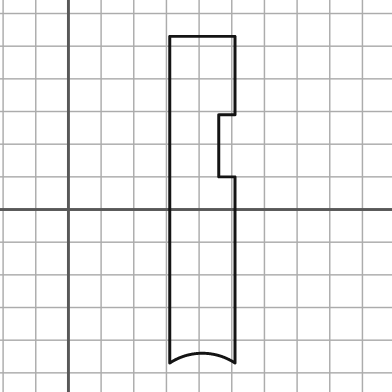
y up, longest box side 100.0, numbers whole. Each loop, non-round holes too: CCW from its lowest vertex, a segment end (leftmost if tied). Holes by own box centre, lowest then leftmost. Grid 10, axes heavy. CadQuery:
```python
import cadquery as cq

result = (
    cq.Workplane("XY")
    .moveTo(31.0, -47.0)
    .threePointArc((41.0, -44.0), (51.0, -47.0))
    .lineTo(51.0, 10.0)
    .lineTo(46.0, 10.0)
    .lineTo(46.0, 29.0)
    .lineTo(51.0, 29.0)
    .lineTo(51.0, 53.0)
    .lineTo(31.0, 53.0)
    .close()
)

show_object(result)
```